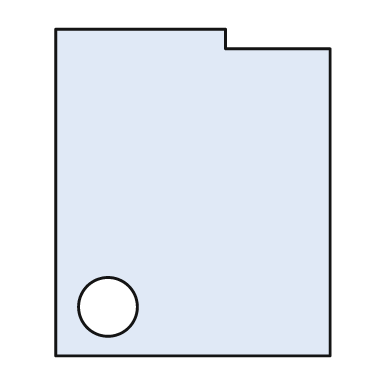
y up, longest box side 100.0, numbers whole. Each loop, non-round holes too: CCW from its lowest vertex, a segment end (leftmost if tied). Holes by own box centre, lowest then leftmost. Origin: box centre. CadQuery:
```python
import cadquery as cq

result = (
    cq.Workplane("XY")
    .moveTo(-42.0, -50.0)
    .lineTo(42.0, -50.0)
    .lineTo(42.0, 44.0)
    .lineTo(10.0, 44.0)
    .lineTo(10.0, 50.0)
    .lineTo(-42.0, 50.0)
    .close()
    .moveTo(-26.0, -35.0)
    .circle(9.0)
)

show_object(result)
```